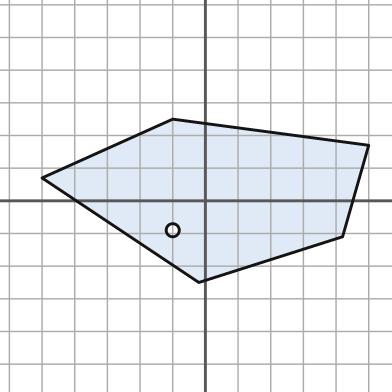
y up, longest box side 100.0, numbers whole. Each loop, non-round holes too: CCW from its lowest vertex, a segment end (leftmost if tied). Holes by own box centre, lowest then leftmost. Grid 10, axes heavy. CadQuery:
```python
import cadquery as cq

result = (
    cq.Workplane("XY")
    .moveTo(-2.0, -25.0)
    .lineTo(42.0, -11.0)
    .lineTo(50.0, 17.0)
    .lineTo(-10.0, 25.0)
    .lineTo(-50.0, 7.0)
    .close()
    .moveTo(-10.0, -9.0)
    .circle(2.0)
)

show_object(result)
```